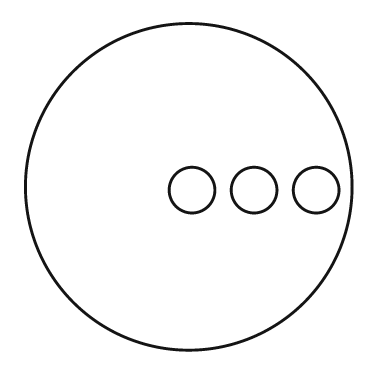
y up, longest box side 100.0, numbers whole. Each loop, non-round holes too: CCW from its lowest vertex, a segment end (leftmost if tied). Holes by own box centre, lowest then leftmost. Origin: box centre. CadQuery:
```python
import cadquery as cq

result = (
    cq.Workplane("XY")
    .moveTo(0.0, 0.0)
    .circle(50.0)
    .moveTo(1.0, -1.0)
    .circle(7.0)
    .moveTo(20.0, -1.0)
    .circle(7.0)
    .moveTo(39.0, -1.0)
    .circle(7.0)
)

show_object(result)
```